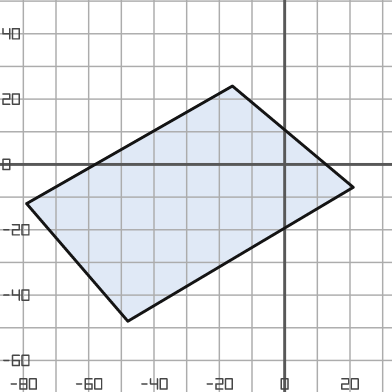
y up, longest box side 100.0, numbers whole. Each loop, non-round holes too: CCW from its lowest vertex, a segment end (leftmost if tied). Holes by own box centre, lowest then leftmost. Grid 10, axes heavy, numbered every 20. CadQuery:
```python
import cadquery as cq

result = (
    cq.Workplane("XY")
    .moveTo(-48.0, -48.0)
    .lineTo(21.0, -7.0)
    .lineTo(-16.0, 24.0)
    .lineTo(-79.0, -12.0)
    .close()
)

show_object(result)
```